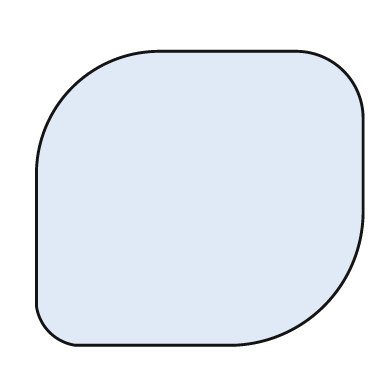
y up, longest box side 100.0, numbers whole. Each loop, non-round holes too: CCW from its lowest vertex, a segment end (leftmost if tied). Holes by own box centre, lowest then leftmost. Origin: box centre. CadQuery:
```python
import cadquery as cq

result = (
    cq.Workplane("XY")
    .moveTo(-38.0, -45.0)
    .lineTo(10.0, -45.0)
    .threePointArc((38.0, -33.0), (50.0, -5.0))
    .lineTo(50.0, 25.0)
    .threePointArc((44.0, 39.0), (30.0, 45.0))
    .lineTo(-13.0, 45.0)
    .threePointArc((-39.0, 34.0), (-50.0, 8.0))
    .lineTo(-50.0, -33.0)
    .threePointArc((-46.0, -41.0), (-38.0, -45.0))
    .close()
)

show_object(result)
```